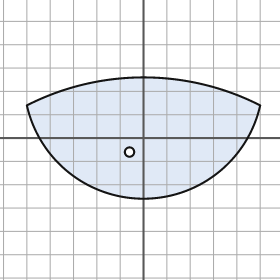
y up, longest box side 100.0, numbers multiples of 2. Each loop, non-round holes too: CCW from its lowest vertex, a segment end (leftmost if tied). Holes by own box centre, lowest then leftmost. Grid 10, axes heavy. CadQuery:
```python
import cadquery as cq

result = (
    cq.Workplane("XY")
    .moveTo(-50.0, 14.0)
    .threePointArc((0.0, -26.0), (50.0, 14.0))
    .threePointArc((0.0, 26.0), (-50.0, 14.0))
    .close()
    .moveTo(-6.0, -6.0)
    .circle(2.0)
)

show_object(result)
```